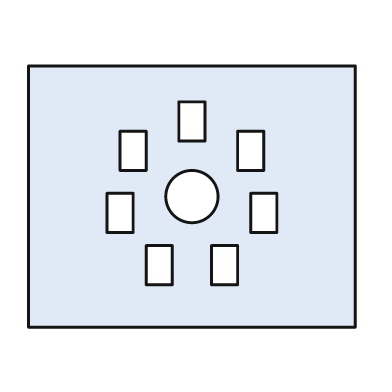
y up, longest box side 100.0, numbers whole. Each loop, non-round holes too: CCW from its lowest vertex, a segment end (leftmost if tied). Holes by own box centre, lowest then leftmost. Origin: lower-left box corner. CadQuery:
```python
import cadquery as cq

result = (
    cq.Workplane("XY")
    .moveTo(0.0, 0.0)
    .lineTo(100.0, 0.0)
    .lineTo(100.0, 80.0)
    .lineTo(0.0, 80.0)
    .close()
    .moveTo(36.0, 13.0)
    .lineTo(44.0, 13.0)
    .lineTo(44.0, 25.0)
    .lineTo(36.0, 25.0)
    .close()
    .moveTo(56.0, 13.0)
    .lineTo(64.0, 13.0)
    .lineTo(64.0, 25.0)
    .lineTo(56.0, 25.0)
    .close()
    .moveTo(24.0, 29.0)
    .lineTo(32.0, 29.0)
    .lineTo(32.0, 41.0)
    .lineTo(24.0, 41.0)
    .close()
    .moveTo(68.0, 29.0)
    .lineTo(76.0, 29.0)
    .lineTo(76.0, 41.0)
    .lineTo(68.0, 41.0)
    .close()
    .moveTo(50.0, 40.0)
    .circle(8.0)
    .moveTo(28.0, 48.0)
    .lineTo(36.0, 48.0)
    .lineTo(36.0, 60.0)
    .lineTo(28.0, 60.0)
    .close()
    .moveTo(64.0, 48.0)
    .lineTo(72.0, 48.0)
    .lineTo(72.0, 60.0)
    .lineTo(64.0, 60.0)
    .close()
    .moveTo(46.0, 57.0)
    .lineTo(54.0, 57.0)
    .lineTo(54.0, 69.0)
    .lineTo(46.0, 69.0)
    .close()
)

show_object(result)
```